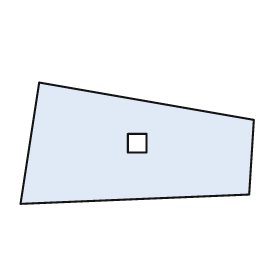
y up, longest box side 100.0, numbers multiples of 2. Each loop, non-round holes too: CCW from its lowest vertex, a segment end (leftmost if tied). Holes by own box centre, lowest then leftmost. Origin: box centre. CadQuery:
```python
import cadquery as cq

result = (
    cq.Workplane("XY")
    .moveTo(-50.0, -26.0)
    .lineTo(48.0, -22.0)
    .lineTo(50.0, 10.0)
    .lineTo(-42.0, 26.0)
    .close()
    .moveTo(-4.0, -4.0)
    .lineTo(4.0, -4.0)
    .lineTo(4.0, 4.0)
    .lineTo(-4.0, 4.0)
    .close()
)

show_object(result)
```